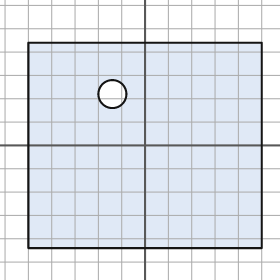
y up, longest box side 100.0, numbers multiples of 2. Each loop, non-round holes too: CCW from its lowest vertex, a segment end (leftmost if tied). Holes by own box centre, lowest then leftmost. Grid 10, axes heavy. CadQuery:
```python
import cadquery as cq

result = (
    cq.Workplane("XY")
    .moveTo(-50.0, -44.0)
    .lineTo(50.0, -44.0)
    .lineTo(50.0, 44.0)
    .lineTo(-50.0, 44.0)
    .close()
    .moveTo(-14.0, 22.0)
    .circle(6.0)
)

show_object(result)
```